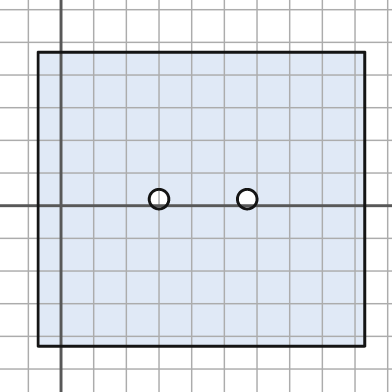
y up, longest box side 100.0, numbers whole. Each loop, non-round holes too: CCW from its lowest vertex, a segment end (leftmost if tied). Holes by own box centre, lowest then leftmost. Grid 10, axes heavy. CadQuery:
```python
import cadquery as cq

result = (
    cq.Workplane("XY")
    .moveTo(-7.0, -43.0)
    .lineTo(93.0, -43.0)
    .lineTo(93.0, 47.0)
    .lineTo(-7.0, 47.0)
    .close()
    .moveTo(30.0, 2.0)
    .circle(3.0)
    .moveTo(57.0, 2.0)
    .circle(3.0)
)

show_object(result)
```